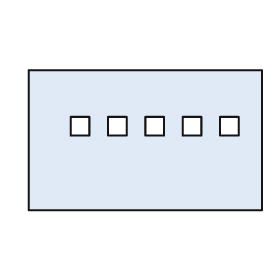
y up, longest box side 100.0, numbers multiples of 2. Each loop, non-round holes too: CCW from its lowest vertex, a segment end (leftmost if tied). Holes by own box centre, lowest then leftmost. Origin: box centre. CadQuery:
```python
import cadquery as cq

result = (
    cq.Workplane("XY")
    .moveTo(-50.0, -30.0)
    .lineTo(50.0, -30.0)
    .lineTo(50.0, 30.0)
    .lineTo(-50.0, 30.0)
    .close()
    .moveTo(-32.0, 2.0)
    .lineTo(-24.0, 2.0)
    .lineTo(-24.0, 10.0)
    .lineTo(-32.0, 10.0)
    .close()
    .moveTo(-16.0, 2.0)
    .lineTo(-8.0, 2.0)
    .lineTo(-8.0, 10.0)
    .lineTo(-16.0, 10.0)
    .close()
    .moveTo(0.0, 2.0)
    .lineTo(8.0, 2.0)
    .lineTo(8.0, 10.0)
    .lineTo(0.0, 10.0)
    .close()
    .moveTo(16.0, 2.0)
    .lineTo(24.0, 2.0)
    .lineTo(24.0, 10.0)
    .lineTo(16.0, 10.0)
    .close()
    .moveTo(32.0, 2.0)
    .lineTo(40.0, 2.0)
    .lineTo(40.0, 10.0)
    .lineTo(32.0, 10.0)
    .close()
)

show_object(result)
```